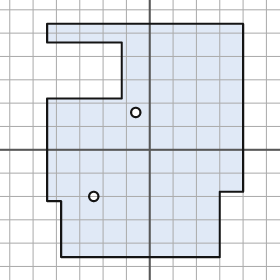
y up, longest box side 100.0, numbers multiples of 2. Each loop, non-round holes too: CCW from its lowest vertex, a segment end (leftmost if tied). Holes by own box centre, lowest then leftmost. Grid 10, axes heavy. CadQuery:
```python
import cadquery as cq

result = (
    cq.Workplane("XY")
    .moveTo(-38.0, -46.0)
    .lineTo(30.0, -46.0)
    .lineTo(30.0, -18.0)
    .lineTo(40.0, -18.0)
    .lineTo(40.0, 54.0)
    .lineTo(-44.0, 54.0)
    .lineTo(-44.0, 46.0)
    .lineTo(-12.0, 46.0)
    .lineTo(-12.0, 22.0)
    .lineTo(-44.0, 22.0)
    .lineTo(-44.0, -22.0)
    .lineTo(-38.0, -22.0)
    .close()
    .moveTo(-24.0, -20.0)
    .circle(2.0)
    .moveTo(-6.0, 16.0)
    .circle(2.0)
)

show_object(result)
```